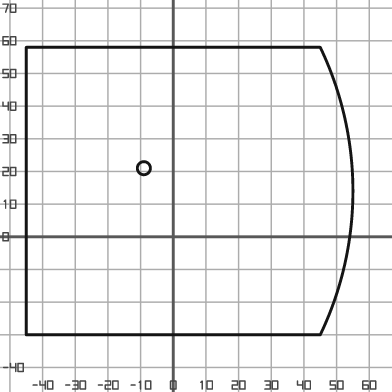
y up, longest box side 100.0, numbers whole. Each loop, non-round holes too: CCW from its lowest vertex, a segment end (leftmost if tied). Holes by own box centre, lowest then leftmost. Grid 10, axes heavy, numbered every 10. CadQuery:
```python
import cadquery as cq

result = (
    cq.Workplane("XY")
    .moveTo(-45.0, -30.0)
    .lineTo(45.0, -30.0)
    .threePointArc((55.0, 14.0), (45.0, 58.0))
    .lineTo(-45.0, 58.0)
    .close()
    .moveTo(-9.0, 21.0)
    .circle(2.0)
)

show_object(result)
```